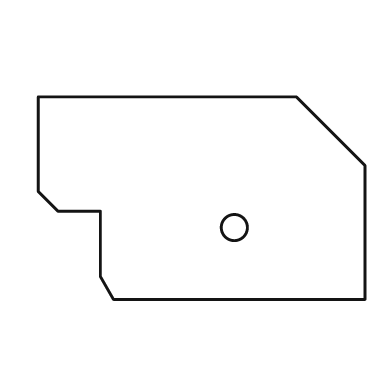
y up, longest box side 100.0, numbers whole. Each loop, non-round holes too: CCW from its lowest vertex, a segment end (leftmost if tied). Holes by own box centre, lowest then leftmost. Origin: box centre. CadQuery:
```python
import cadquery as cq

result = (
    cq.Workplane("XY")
    .moveTo(-27.0, -31.0)
    .lineTo(50.0, -31.0)
    .lineTo(50.0, 10.0)
    .lineTo(29.0, 31.0)
    .lineTo(-50.0, 31.0)
    .lineTo(-50.0, 2.0)
    .lineTo(-44.0, -4.0)
    .lineTo(-31.0, -4.0)
    .lineTo(-31.0, -24.0)
    .close()
    .moveTo(10.0, -9.0)
    .circle(4.0)
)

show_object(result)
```